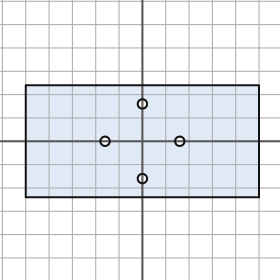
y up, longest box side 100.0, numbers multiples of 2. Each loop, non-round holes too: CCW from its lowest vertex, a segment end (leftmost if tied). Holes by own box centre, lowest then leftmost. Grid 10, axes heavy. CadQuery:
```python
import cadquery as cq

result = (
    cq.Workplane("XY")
    .moveTo(-50.0, -24.0)
    .lineTo(50.0, -24.0)
    .lineTo(50.0, 24.0)
    .lineTo(-50.0, 24.0)
    .close()
    .moveTo(0.0, -16.0)
    .circle(2.0)
    .moveTo(-16.0, 0.0)
    .circle(2.0)
    .moveTo(16.0, 0.0)
    .circle(2.0)
    .moveTo(0.0, 16.0)
    .circle(2.0)
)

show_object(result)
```